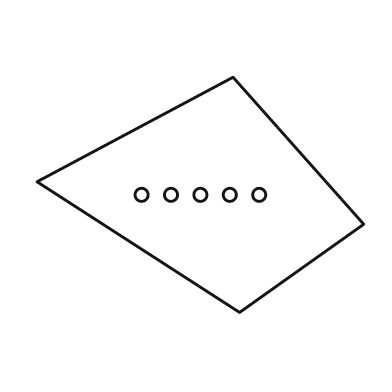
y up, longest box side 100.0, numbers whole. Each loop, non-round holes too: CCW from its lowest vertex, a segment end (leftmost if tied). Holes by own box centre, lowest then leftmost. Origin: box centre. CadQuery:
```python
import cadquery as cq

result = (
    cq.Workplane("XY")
    .moveTo(12.0, -36.0)
    .lineTo(50.0, -9.0)
    .lineTo(10.0, 36.0)
    .lineTo(-50.0, 4.0)
    .close()
    .moveTo(-18.0, 0.0)
    .circle(2.0)
    .moveTo(-9.0, 0.0)
    .circle(2.0)
    .moveTo(0.0, 0.0)
    .circle(2.0)
    .moveTo(9.0, 0.0)
    .circle(2.0)
    .moveTo(18.0, 0.0)
    .circle(2.0)
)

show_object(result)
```